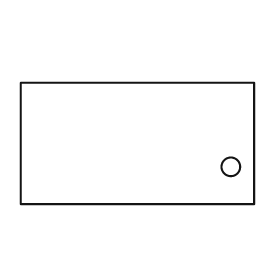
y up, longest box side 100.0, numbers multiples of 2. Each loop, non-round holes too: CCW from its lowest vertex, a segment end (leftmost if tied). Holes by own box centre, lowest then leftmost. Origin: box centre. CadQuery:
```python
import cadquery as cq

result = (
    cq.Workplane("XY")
    .moveTo(-50.0, -26.0)
    .lineTo(50.0, -26.0)
    .lineTo(50.0, 26.0)
    .lineTo(-50.0, 26.0)
    .close()
    .moveTo(40.0, -10.0)
    .circle(4.0)
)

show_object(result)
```